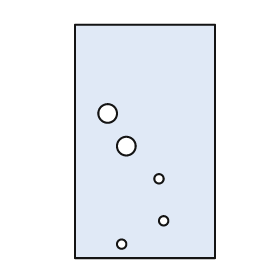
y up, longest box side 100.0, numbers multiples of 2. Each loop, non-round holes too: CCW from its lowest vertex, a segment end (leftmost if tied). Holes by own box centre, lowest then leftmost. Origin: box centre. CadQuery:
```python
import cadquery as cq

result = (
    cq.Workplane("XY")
    .moveTo(-30.0, -50.0)
    .lineTo(30.0, -50.0)
    .lineTo(30.0, 50.0)
    .lineTo(-30.0, 50.0)
    .close()
    .moveTo(-10.0, -44.0)
    .circle(2.0)
    .moveTo(8.0, -34.0)
    .circle(2.0)
    .moveTo(6.0, -16.0)
    .circle(2.0)
    .moveTo(-8.0, -2.0)
    .circle(4.0)
    .moveTo(-16.0, 12.0)
    .circle(4.0)
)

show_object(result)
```